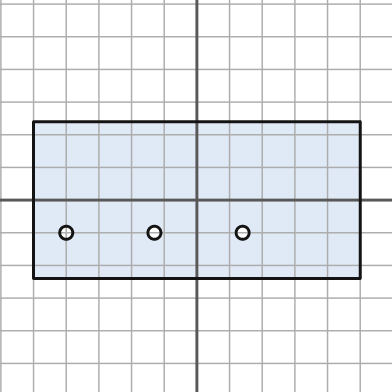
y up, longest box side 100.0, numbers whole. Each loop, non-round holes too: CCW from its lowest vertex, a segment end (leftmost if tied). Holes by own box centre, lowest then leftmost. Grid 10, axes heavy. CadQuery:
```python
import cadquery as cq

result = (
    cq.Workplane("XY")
    .moveTo(-50.0, -24.0)
    .lineTo(50.0, -24.0)
    .lineTo(50.0, 24.0)
    .lineTo(-50.0, 24.0)
    .close()
    .moveTo(-40.0, -10.0)
    .circle(2.0)
    .moveTo(-13.0, -10.0)
    .circle(2.0)
    .moveTo(14.0, -10.0)
    .circle(2.0)
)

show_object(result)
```